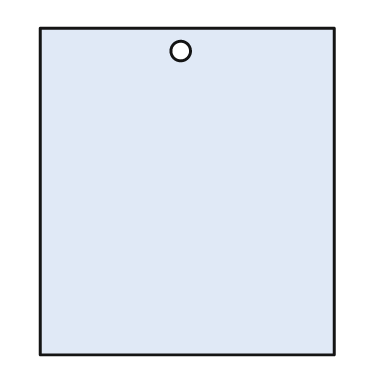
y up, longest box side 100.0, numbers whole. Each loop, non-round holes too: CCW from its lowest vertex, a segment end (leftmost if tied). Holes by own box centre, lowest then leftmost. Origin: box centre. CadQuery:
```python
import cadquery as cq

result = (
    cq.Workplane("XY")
    .moveTo(-45.0, -50.0)
    .lineTo(45.0, -50.0)
    .lineTo(45.0, 50.0)
    .lineTo(-45.0, 50.0)
    .close()
    .moveTo(-2.0, 43.0)
    .circle(3.0)
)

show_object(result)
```